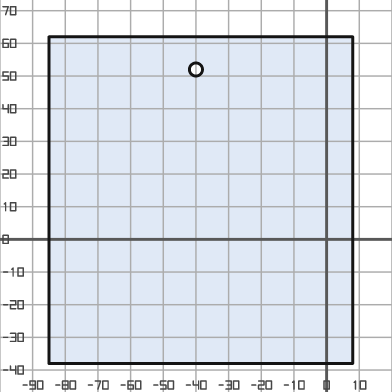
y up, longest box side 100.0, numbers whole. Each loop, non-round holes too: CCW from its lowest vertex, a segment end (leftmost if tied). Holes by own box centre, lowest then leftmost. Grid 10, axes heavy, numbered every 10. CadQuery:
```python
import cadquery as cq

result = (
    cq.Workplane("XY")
    .moveTo(-85.0, -38.0)
    .lineTo(8.0, -38.0)
    .lineTo(8.0, 62.0)
    .lineTo(-85.0, 62.0)
    .close()
    .moveTo(-40.0, 52.0)
    .circle(2.0)
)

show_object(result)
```